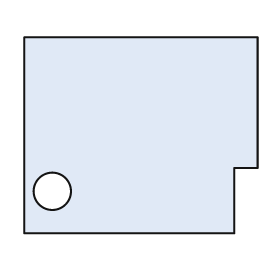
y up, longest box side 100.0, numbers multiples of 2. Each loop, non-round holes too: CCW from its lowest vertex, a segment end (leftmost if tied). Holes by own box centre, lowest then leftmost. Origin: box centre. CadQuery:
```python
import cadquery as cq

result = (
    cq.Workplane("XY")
    .moveTo(-50.0, -42.0)
    .lineTo(40.0, -42.0)
    .lineTo(40.0, -14.0)
    .lineTo(50.0, -14.0)
    .lineTo(50.0, 42.0)
    .lineTo(-50.0, 42.0)
    .close()
    .moveTo(-38.0, -24.0)
    .circle(8.0)
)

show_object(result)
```